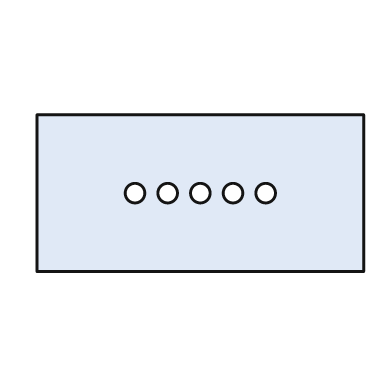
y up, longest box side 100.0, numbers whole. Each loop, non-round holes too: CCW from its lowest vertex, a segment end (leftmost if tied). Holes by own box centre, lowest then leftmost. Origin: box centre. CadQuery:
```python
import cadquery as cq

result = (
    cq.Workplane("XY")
    .moveTo(-50.0, -24.0)
    .lineTo(50.0, -24.0)
    .lineTo(50.0, 24.0)
    .lineTo(-50.0, 24.0)
    .close()
    .moveTo(-20.0, 0.0)
    .circle(3.0)
    .moveTo(-10.0, 0.0)
    .circle(3.0)
    .moveTo(0.0, 0.0)
    .circle(3.0)
    .moveTo(10.0, 0.0)
    .circle(3.0)
    .moveTo(20.0, 0.0)
    .circle(3.0)
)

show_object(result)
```